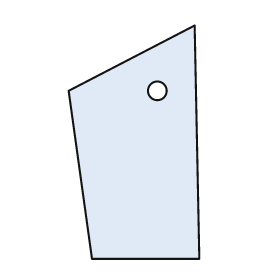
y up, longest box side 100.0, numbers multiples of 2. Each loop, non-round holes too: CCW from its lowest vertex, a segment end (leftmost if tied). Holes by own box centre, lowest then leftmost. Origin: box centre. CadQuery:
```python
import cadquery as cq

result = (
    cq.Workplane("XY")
    .moveTo(-18.0, -50.0)
    .lineTo(28.0, -50.0)
    .lineTo(26.0, 50.0)
    .lineTo(-28.0, 22.0)
    .close()
    .moveTo(10.0, 22.0)
    .circle(4.0)
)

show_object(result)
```